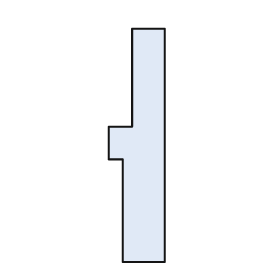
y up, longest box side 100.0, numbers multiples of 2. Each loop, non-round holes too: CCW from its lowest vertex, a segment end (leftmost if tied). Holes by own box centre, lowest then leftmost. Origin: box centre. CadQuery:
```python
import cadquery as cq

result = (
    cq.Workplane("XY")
    .moveTo(-6.0, -50.0)
    .lineTo(12.0, -50.0)
    .lineTo(12.0, 50.0)
    .lineTo(-2.0, 50.0)
    .lineTo(-2.0, 8.0)
    .lineTo(-12.0, 8.0)
    .lineTo(-12.0, -6.0)
    .lineTo(-6.0, -6.0)
    .close()
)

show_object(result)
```